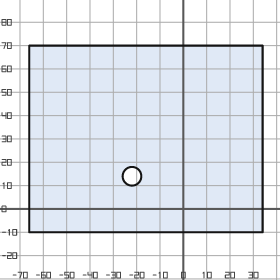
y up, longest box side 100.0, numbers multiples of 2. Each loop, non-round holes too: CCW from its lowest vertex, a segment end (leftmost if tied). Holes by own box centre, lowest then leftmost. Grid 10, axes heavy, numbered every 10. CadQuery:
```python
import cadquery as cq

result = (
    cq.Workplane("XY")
    .moveTo(-66.0, -10.0)
    .lineTo(34.0, -10.0)
    .lineTo(34.0, 70.0)
    .lineTo(-66.0, 70.0)
    .close()
    .moveTo(-22.0, 14.0)
    .circle(4.0)
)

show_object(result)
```